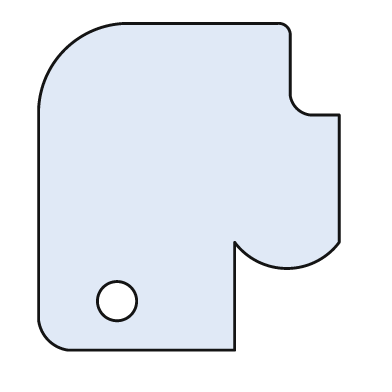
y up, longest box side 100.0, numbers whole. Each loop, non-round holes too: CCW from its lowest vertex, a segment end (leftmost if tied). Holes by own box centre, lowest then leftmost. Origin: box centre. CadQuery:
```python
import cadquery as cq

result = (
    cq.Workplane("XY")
    .moveTo(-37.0, -50.0)
    .lineTo(14.0, -50.0)
    .lineTo(14.0, -17.0)
    .threePointArc((30.0, -25.0), (46.0, -17.0))
    .lineTo(46.0, 22.0)
    .lineTo(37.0, 22.0)
    .threePointArc((33.0, 24.0), (31.0, 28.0))
    .lineTo(31.0, 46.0)
    .threePointArc((30.0, 49.0), (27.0, 50.0))
    .lineTo(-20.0, 50.0)
    .threePointArc((-38.0, 42.0), (-46.0, 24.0))
    .lineTo(-46.0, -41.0)
    .threePointArc((-43.0, -47.0), (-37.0, -50.0))
    .close()
    .moveTo(-22.0, -35.0)
    .circle(6.0)
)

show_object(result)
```